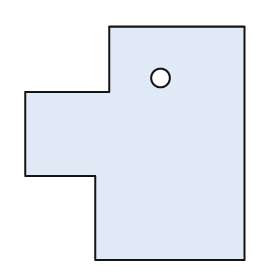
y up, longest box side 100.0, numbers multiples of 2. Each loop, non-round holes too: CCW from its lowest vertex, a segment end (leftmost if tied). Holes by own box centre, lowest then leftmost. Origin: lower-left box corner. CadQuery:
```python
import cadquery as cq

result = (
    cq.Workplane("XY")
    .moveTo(30.0, 0.0)
    .lineTo(94.0, 0.0)
    .lineTo(94.0, 100.0)
    .lineTo(36.0, 100.0)
    .lineTo(36.0, 72.0)
    .lineTo(0.0, 72.0)
    .lineTo(0.0, 36.0)
    .lineTo(30.0, 36.0)
    .close()
    .moveTo(58.0, 78.0)
    .circle(4.0)
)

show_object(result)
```